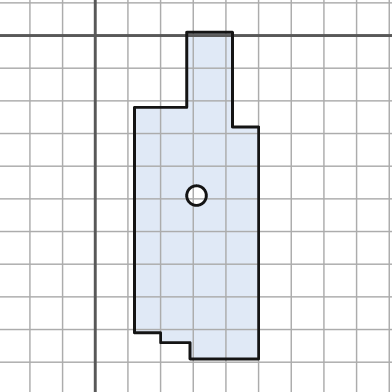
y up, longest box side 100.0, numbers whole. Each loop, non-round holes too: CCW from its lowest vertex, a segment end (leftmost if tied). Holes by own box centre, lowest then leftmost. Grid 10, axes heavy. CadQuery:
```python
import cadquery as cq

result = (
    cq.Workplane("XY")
    .moveTo(29.0, -99.0)
    .lineTo(50.0, -99.0)
    .lineTo(50.0, -28.0)
    .lineTo(42.0, -28.0)
    .lineTo(42.0, 1.0)
    .lineTo(28.0, 1.0)
    .lineTo(28.0, -22.0)
    .lineTo(12.0, -22.0)
    .lineTo(12.0, -91.0)
    .lineTo(20.0, -91.0)
    .lineTo(20.0, -94.0)
    .lineTo(29.0, -94.0)
    .close()
    .moveTo(31.0, -49.0)
    .circle(3.0)
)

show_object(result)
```